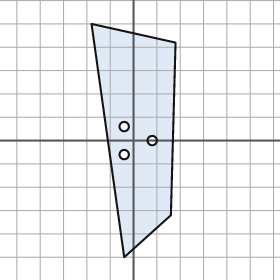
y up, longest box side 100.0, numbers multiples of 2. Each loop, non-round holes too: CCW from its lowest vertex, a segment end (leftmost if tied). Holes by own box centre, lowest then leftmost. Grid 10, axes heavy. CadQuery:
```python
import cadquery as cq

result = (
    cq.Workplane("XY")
    .moveTo(-4.0, -50.0)
    .lineTo(16.0, -32.0)
    .lineTo(18.0, 42.0)
    .lineTo(-18.0, 50.0)
    .close()
    .moveTo(-4.0, -6.0)
    .circle(2.0)
    .moveTo(8.0, 0.0)
    .circle(2.0)
    .moveTo(-4.0, 6.0)
    .circle(2.0)
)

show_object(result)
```